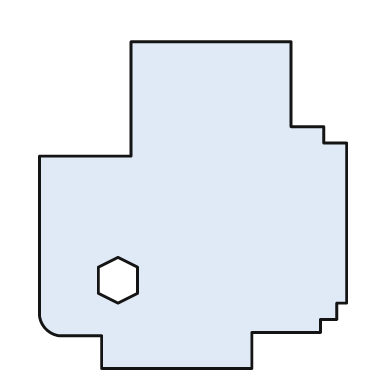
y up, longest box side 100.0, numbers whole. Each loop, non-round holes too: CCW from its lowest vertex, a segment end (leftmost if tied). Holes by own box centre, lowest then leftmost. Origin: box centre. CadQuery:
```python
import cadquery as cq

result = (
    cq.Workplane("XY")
    .moveTo(-28.0, -50.0)
    .lineTo(18.0, -50.0)
    .lineTo(18.0, -39.0)
    .lineTo(39.0, -39.0)
    .lineTo(39.0, -35.0)
    .lineTo(44.0, -35.0)
    .lineTo(44.0, -30.0)
    .lineTo(47.0, -30.0)
    .lineTo(47.0, 19.0)
    .lineTo(40.0, 19.0)
    .lineTo(40.0, 24.0)
    .lineTo(30.0, 24.0)
    .lineTo(30.0, 50.0)
    .lineTo(-19.0, 50.0)
    .lineTo(-19.0, 15.0)
    .lineTo(-47.0, 15.0)
    .lineTo(-47.0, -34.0)
    .threePointArc((-45.0, -38.0), (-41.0, -40.0))
    .lineTo(-28.0, -40.0)
    .close()
    .moveTo(-23.0, -30.0)
    .lineTo(-17.0, -27.0)
    .lineTo(-17.0, -19.0)
    .lineTo(-23.0, -16.0)
    .lineTo(-29.0, -19.0)
    .lineTo(-29.0, -27.0)
    .close()
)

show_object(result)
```